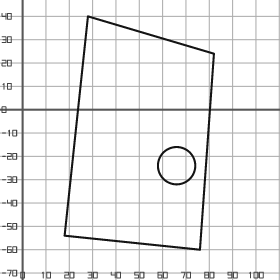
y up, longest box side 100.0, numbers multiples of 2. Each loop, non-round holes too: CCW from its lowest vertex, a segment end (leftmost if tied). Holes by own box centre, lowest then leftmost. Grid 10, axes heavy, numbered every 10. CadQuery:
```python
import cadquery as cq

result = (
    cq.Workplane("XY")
    .moveTo(76.0, -60.0)
    .lineTo(82.0, 24.0)
    .lineTo(28.0, 40.0)
    .lineTo(18.0, -54.0)
    .close()
    .moveTo(66.0, -24.0)
    .circle(8.0)
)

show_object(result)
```